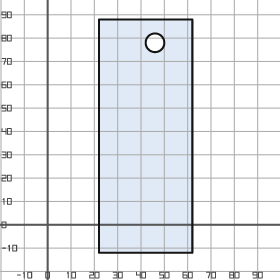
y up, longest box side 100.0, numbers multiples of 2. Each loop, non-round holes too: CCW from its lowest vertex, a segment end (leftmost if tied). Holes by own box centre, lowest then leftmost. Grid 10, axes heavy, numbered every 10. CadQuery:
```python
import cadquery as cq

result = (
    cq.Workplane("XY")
    .moveTo(22.0, -12.0)
    .lineTo(62.0, -12.0)
    .lineTo(62.0, 88.0)
    .lineTo(22.0, 88.0)
    .close()
    .moveTo(46.0, 78.0)
    .circle(4.0)
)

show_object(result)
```